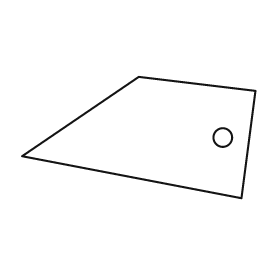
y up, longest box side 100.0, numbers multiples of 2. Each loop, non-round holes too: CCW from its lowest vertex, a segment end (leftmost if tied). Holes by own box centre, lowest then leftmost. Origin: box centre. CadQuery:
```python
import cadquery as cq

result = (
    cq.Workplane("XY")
    .moveTo(44.0, -26.0)
    .lineTo(50.0, 20.0)
    .lineTo(0.0, 26.0)
    .lineTo(-50.0, -8.0)
    .close()
    .moveTo(36.0, 0.0)
    .circle(4.0)
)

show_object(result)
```